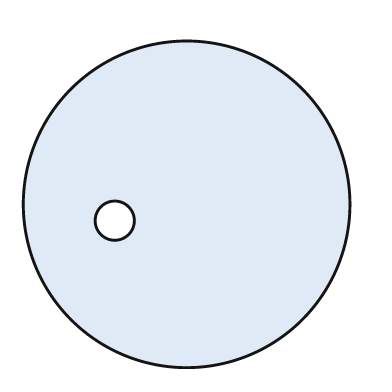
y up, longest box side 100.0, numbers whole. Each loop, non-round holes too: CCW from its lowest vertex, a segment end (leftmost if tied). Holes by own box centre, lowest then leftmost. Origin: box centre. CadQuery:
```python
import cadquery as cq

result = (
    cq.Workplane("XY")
    .moveTo(0.0, 0.0)
    .circle(50.0)
    .moveTo(-22.0, -5.0)
    .circle(6.0)
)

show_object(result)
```